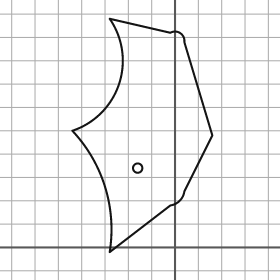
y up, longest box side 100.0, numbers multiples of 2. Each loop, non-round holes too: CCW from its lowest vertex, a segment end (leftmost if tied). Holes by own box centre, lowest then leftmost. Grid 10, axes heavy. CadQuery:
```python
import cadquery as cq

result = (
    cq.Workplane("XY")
    .moveTo(-28.0, -2.0)
    .lineTo(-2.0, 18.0)
    .threePointArc((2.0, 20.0), (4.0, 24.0))
    .lineTo(16.0, 48.0)
    .lineTo(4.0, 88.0)
    .threePointArc((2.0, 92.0), (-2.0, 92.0))
    .lineTo(-28.0, 98.0)
    .threePointArc((-24.0, 70.0), (-44.0, 50.0))
    .threePointArc((-30.0, 26.0), (-28.0, -2.0))
    .close()
    .moveTo(-16.0, 34.0)
    .circle(2.0)
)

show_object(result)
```